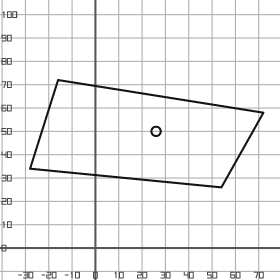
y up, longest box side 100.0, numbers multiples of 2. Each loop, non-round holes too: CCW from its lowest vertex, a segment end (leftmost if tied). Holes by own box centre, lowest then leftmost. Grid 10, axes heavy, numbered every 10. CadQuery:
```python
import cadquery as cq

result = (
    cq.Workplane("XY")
    .moveTo(54.0, 26.0)
    .lineTo(72.0, 58.0)
    .lineTo(-16.0, 72.0)
    .lineTo(-28.0, 34.0)
    .close()
    .moveTo(26.0, 50.0)
    .circle(2.0)
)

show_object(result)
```